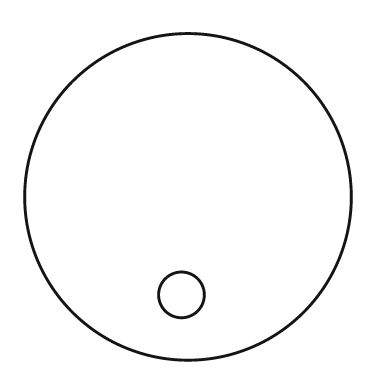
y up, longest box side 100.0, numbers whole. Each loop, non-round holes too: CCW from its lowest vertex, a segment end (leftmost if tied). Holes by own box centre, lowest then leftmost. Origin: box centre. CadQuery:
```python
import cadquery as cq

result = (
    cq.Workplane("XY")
    .moveTo(0.0, 0.0)
    .circle(50.0)
    .moveTo(-2.0, -30.0)
    .circle(7.0)
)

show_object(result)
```